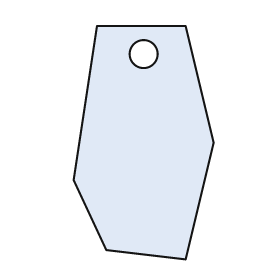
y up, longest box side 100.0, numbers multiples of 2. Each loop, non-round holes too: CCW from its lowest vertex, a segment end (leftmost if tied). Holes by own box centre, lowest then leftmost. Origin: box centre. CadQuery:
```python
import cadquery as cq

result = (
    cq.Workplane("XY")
    .moveTo(18.0, -50.0)
    .lineTo(30.0, 0.0)
    .lineTo(18.0, 50.0)
    .lineTo(-20.0, 50.0)
    .lineTo(-30.0, -16.0)
    .lineTo(-16.0, -46.0)
    .close()
    .moveTo(0.0, 38.0)
    .circle(6.0)
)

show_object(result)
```